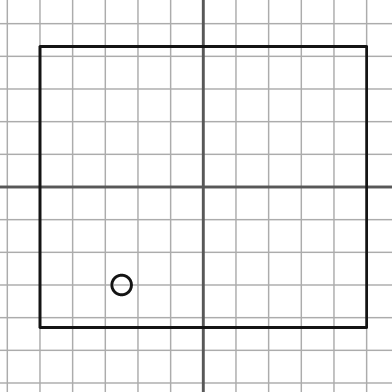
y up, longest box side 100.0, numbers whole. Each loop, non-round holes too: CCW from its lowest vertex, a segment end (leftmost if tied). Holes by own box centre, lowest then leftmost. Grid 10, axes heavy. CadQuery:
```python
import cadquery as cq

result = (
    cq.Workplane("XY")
    .moveTo(-50.0, -43.0)
    .lineTo(50.0, -43.0)
    .lineTo(50.0, 43.0)
    .lineTo(-50.0, 43.0)
    .close()
    .moveTo(-25.0, -30.0)
    .circle(3.0)
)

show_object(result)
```